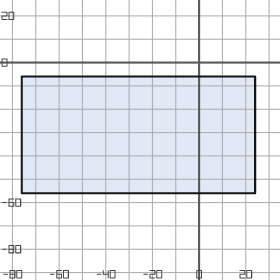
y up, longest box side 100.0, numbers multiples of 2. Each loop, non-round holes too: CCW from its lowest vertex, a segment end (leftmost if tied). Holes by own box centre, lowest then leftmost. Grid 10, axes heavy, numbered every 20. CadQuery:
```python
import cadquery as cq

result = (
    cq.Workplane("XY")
    .moveTo(-76.0, -56.0)
    .lineTo(24.0, -56.0)
    .lineTo(24.0, -6.0)
    .lineTo(-76.0, -6.0)
    .close()
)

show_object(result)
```